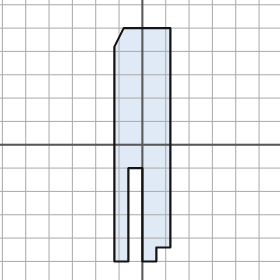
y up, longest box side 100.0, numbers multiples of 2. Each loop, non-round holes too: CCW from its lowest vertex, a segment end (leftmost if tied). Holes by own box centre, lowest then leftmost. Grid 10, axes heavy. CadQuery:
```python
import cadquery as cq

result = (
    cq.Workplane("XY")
    .moveTo(-12.0, -50.0)
    .lineTo(-6.0, -50.0)
    .lineTo(-6.0, -10.0)
    .lineTo(0.0, -10.0)
    .lineTo(0.0, -50.0)
    .lineTo(6.0, -50.0)
    .lineTo(6.0, -44.0)
    .lineTo(12.0, -44.0)
    .lineTo(12.0, 50.0)
    .lineTo(-8.0, 50.0)
    .lineTo(-12.0, 42.0)
    .close()
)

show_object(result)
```